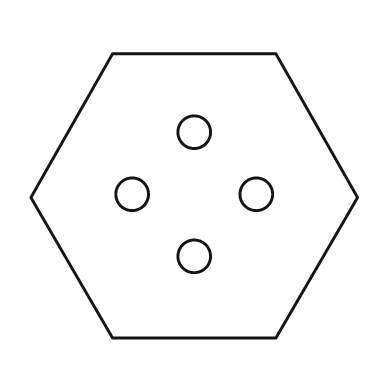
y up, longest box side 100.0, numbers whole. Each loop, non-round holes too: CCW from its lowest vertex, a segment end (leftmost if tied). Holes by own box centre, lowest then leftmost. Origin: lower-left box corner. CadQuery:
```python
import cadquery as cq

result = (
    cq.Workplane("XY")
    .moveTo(25.0, 0.0)
    .lineTo(75.0, 0.0)
    .lineTo(100.0, 43.0)
    .lineTo(75.0, 87.0)
    .lineTo(25.0, 87.0)
    .lineTo(0.0, 43.0)
    .close()
    .moveTo(50.0, 25.0)
    .circle(5.0)
    .moveTo(31.0, 44.0)
    .circle(5.0)
    .moveTo(69.0, 44.0)
    .circle(5.0)
    .moveTo(50.0, 63.0)
    .circle(5.0)
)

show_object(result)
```